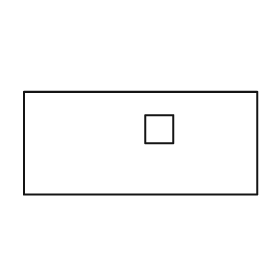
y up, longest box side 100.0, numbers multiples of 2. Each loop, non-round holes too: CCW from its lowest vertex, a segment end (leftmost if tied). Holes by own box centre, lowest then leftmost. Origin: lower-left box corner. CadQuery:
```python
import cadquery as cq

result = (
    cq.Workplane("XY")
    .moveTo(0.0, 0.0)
    .lineTo(100.0, 0.0)
    .lineTo(100.0, 44.0)
    .lineTo(0.0, 44.0)
    .close()
    .moveTo(52.0, 22.0)
    .lineTo(64.0, 22.0)
    .lineTo(64.0, 34.0)
    .lineTo(52.0, 34.0)
    .close()
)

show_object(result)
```